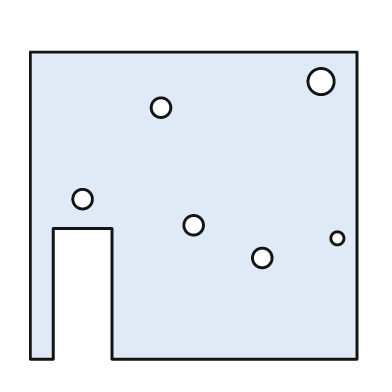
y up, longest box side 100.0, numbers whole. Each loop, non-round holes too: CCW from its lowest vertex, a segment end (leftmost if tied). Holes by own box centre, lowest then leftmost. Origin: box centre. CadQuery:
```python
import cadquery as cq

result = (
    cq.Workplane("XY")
    .moveTo(-50.0, -47.0)
    .lineTo(-43.0, -47.0)
    .lineTo(-43.0, -7.0)
    .lineTo(-25.0, -7.0)
    .lineTo(-25.0, -47.0)
    .lineTo(50.0, -47.0)
    .lineTo(50.0, 47.0)
    .lineTo(-50.0, 47.0)
    .close()
    .moveTo(21.0, -16.0)
    .circle(3.0)
    .moveTo(44.0, -10.0)
    .circle(2.0)
    .moveTo(0.0, -6.0)
    .circle(3.0)
    .moveTo(-34.0, 2.0)
    .circle(3.0)
    .moveTo(-10.0, 30.0)
    .circle(3.0)
    .moveTo(39.0, 38.0)
    .circle(4.0)
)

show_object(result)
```